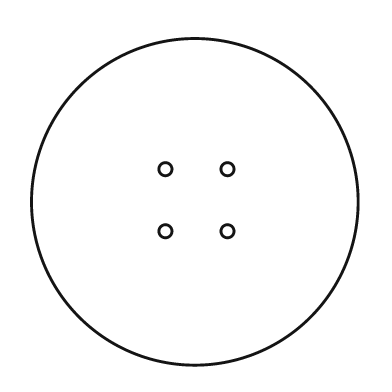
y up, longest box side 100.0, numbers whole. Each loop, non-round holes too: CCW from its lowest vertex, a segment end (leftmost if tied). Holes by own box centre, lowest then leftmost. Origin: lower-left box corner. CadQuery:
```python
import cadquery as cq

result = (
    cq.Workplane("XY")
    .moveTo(50.0, 50.0)
    .circle(50.0)
    .moveTo(41.0, 41.0)
    .circle(2.0)
    .moveTo(60.0, 41.0)
    .circle(2.0)
    .moveTo(41.0, 60.0)
    .circle(2.0)
    .moveTo(60.0, 60.0)
    .circle(2.0)
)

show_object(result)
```